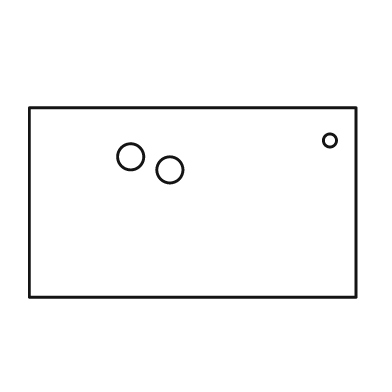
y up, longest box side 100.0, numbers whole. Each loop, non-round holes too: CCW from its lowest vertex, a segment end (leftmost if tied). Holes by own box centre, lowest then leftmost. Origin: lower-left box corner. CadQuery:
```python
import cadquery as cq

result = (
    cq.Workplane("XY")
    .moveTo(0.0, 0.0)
    .lineTo(100.0, 0.0)
    .lineTo(100.0, 58.0)
    .lineTo(0.0, 58.0)
    .close()
    .moveTo(43.0, 39.0)
    .circle(4.0)
    .moveTo(31.0, 43.0)
    .circle(4.0)
    .moveTo(92.0, 48.0)
    .circle(2.0)
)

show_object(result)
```